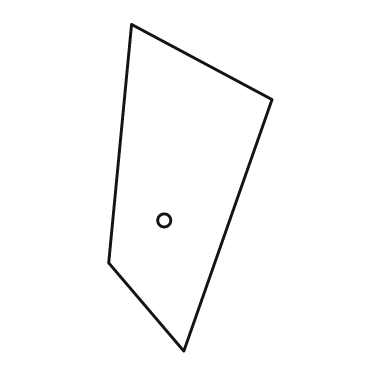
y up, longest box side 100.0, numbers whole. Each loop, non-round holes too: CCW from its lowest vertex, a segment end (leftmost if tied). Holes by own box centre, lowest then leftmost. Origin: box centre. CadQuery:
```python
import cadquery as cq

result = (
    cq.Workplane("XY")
    .moveTo(-2.0, -50.0)
    .lineTo(25.0, 27.0)
    .lineTo(-18.0, 50.0)
    .lineTo(-25.0, -23.0)
    .close()
    .moveTo(-8.0, -10.0)
    .circle(2.0)
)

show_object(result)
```